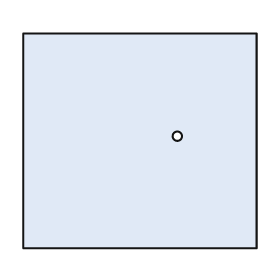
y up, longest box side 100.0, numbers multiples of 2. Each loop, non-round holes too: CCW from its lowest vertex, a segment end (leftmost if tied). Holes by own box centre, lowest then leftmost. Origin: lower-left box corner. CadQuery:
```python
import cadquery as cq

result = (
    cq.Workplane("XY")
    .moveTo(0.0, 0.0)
    .lineTo(100.0, 0.0)
    .lineTo(100.0, 92.0)
    .lineTo(0.0, 92.0)
    .close()
    .moveTo(66.0, 48.0)
    .circle(2.0)
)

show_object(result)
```